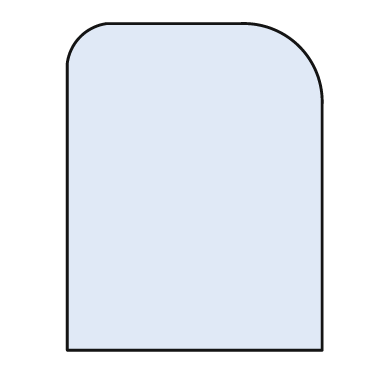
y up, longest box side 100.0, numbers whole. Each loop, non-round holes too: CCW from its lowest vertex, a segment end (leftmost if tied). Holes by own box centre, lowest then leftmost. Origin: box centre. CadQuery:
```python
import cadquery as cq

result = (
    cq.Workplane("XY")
    .moveTo(-39.0, -50.0)
    .lineTo(39.0, -50.0)
    .lineTo(39.0, 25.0)
    .threePointArc((32.0, 43.0), (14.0, 50.0))
    .lineTo(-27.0, 50.0)
    .threePointArc((-35.0, 46.0), (-39.0, 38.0))
    .close()
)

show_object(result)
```